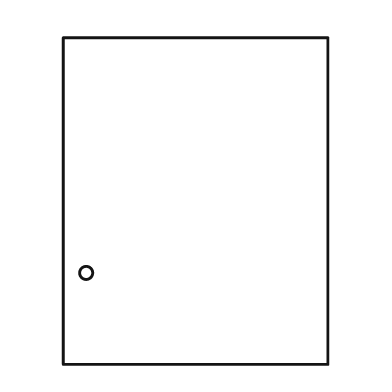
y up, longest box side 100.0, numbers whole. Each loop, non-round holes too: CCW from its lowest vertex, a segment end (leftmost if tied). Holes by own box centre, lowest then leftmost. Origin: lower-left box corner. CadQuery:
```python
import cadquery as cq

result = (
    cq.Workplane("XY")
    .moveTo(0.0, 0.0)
    .lineTo(81.0, 0.0)
    .lineTo(81.0, 100.0)
    .lineTo(0.0, 100.0)
    .close()
    .moveTo(7.0, 28.0)
    .circle(2.0)
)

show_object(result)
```